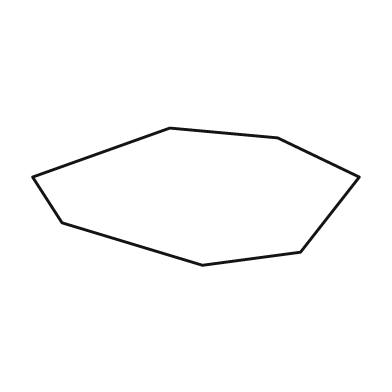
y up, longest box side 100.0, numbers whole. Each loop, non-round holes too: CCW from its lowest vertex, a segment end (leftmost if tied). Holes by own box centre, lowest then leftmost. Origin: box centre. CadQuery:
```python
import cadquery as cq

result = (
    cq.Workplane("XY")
    .moveTo(2.0, -21.0)
    .lineTo(32.0, -17.0)
    .lineTo(50.0, 6.0)
    .lineTo(25.0, 18.0)
    .lineTo(-8.0, 21.0)
    .lineTo(-50.0, 6.0)
    .lineTo(-41.0, -8.0)
    .close()
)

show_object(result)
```